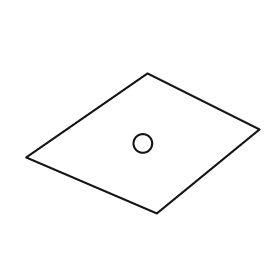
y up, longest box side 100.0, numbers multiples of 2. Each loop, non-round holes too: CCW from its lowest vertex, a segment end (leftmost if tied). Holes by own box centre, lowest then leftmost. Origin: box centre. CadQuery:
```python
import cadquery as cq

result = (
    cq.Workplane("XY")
    .moveTo(6.0, -30.0)
    .lineTo(50.0, 6.0)
    .lineTo(2.0, 30.0)
    .lineTo(-50.0, -6.0)
    .close()
    .moveTo(0.0, 0.0)
    .circle(4.0)
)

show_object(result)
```